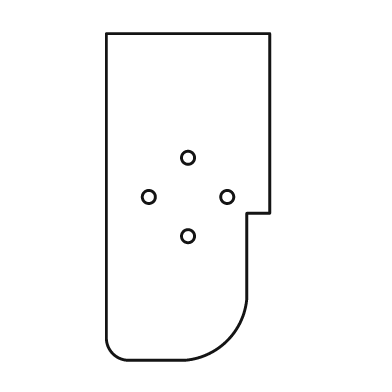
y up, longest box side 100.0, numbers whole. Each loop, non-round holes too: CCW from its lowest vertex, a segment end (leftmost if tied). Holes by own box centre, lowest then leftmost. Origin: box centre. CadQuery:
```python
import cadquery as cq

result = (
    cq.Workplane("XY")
    .moveTo(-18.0, -50.0)
    .lineTo(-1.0, -50.0)
    .threePointArc((12.0, -44.0), (18.0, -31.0))
    .lineTo(18.0, -5.0)
    .lineTo(25.0, -5.0)
    .lineTo(25.0, 50.0)
    .lineTo(-25.0, 50.0)
    .lineTo(-25.0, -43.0)
    .threePointArc((-23.0, -48.0), (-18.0, -50.0))
    .close()
    .moveTo(0.0, -12.0)
    .circle(2.0)
    .moveTo(-12.0, 0.0)
    .circle(2.0)
    .moveTo(12.0, 0.0)
    .circle(2.0)
    .moveTo(0.0, 12.0)
    .circle(2.0)
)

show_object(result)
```